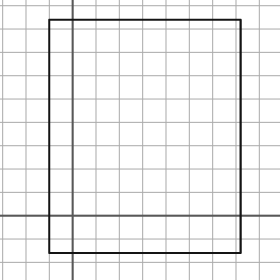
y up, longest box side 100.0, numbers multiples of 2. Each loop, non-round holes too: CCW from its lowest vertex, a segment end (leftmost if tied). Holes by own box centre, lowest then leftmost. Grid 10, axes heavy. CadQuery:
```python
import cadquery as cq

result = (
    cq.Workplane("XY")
    .moveTo(-10.0, -16.0)
    .lineTo(72.0, -16.0)
    .lineTo(72.0, 84.0)
    .lineTo(-10.0, 84.0)
    .close()
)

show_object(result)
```